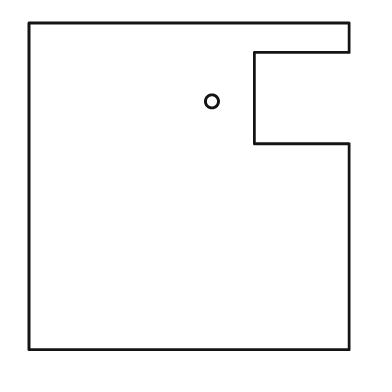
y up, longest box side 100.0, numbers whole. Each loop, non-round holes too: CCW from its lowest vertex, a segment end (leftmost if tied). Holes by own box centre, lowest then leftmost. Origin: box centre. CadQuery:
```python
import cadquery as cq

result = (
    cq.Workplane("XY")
    .moveTo(-49.0, -50.0)
    .lineTo(49.0, -50.0)
    .lineTo(49.0, 13.0)
    .lineTo(20.0, 13.0)
    .lineTo(20.0, 41.0)
    .lineTo(49.0, 41.0)
    .lineTo(49.0, 50.0)
    .lineTo(-49.0, 50.0)
    .close()
    .moveTo(7.0, 26.0)
    .circle(2.0)
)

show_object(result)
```